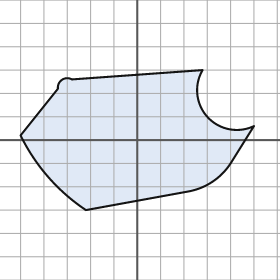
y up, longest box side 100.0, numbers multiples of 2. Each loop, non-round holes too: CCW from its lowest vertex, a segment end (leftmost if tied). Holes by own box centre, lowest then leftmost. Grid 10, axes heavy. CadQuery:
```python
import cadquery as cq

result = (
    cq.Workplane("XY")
    .moveTo(-22.0, -30.0)
    .lineTo(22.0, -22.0)
    .threePointArc((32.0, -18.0), (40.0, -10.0))
    .lineTo(50.0, 6.0)
    .threePointArc((30.0, 10.0), (28.0, 30.0))
    .lineTo(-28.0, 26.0)
    .threePointArc((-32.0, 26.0), (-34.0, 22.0))
    .lineTo(-50.0, 2.0)
    .threePointArc((-38.0, -16.0), (-22.0, -30.0))
    .close()
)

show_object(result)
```